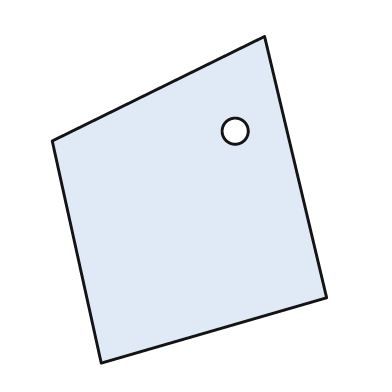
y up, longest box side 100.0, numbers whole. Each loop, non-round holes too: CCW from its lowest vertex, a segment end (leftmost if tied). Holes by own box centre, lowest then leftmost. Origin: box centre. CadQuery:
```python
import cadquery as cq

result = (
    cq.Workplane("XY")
    .moveTo(-27.0, -50.0)
    .lineTo(42.0, -30.0)
    .lineTo(23.0, 50.0)
    .lineTo(-42.0, 18.0)
    .close()
    .moveTo(14.0, 21.0)
    .circle(4.0)
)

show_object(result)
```